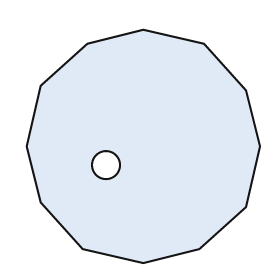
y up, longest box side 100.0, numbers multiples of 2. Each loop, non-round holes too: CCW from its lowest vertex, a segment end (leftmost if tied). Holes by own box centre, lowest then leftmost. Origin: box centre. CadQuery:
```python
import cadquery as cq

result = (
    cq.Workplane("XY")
    .moveTo(0.0, -50.0)
    .lineTo(24.0, -44.0)
    .lineTo(44.0, -26.0)
    .lineTo(50.0, 0.0)
    .lineTo(44.0, 24.0)
    .lineTo(26.0, 44.0)
    .lineTo(0.0, 50.0)
    .lineTo(-24.0, 44.0)
    .lineTo(-44.0, 26.0)
    .lineTo(-50.0, 0.0)
    .lineTo(-44.0, -24.0)
    .lineTo(-26.0, -44.0)
    .close()
    .moveTo(-16.0, -8.0)
    .circle(6.0)
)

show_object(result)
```